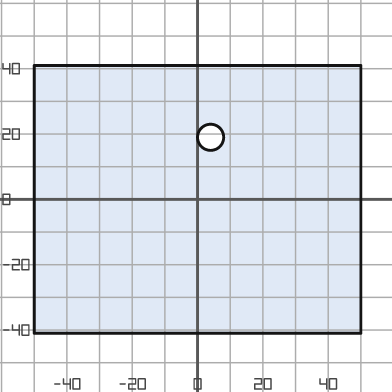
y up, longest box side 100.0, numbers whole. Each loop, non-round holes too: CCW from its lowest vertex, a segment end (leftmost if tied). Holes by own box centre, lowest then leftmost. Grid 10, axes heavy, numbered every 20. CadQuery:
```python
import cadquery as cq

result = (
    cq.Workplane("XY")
    .moveTo(-50.0, -41.0)
    .lineTo(50.0, -41.0)
    .lineTo(50.0, 41.0)
    .lineTo(-50.0, 41.0)
    .close()
    .moveTo(4.0, 19.0)
    .circle(4.0)
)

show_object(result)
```